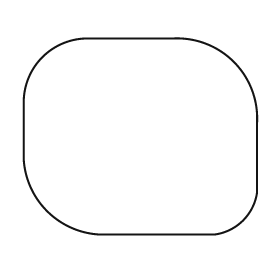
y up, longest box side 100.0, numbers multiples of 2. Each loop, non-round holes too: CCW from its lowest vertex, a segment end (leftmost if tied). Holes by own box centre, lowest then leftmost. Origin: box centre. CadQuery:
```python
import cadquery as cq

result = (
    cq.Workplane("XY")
    .moveTo(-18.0, -42.0)
    .lineTo(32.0, -42.0)
    .threePointArc((44.0, -36.0), (50.0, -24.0))
    .lineTo(50.0, 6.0)
    .threePointArc((40.0, 32.0), (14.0, 42.0))
    .lineTo(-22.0, 42.0)
    .threePointArc((-42.0, 34.0), (-50.0, 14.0))
    .lineTo(-50.0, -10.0)
    .threePointArc((-40.0, -32.0), (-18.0, -42.0))
    .close()
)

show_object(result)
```